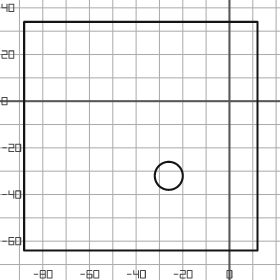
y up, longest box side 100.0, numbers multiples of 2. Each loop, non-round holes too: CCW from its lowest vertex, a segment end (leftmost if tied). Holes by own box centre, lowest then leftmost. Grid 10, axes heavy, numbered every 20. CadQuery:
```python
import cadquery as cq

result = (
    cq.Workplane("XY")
    .moveTo(-88.0, -64.0)
    .lineTo(12.0, -64.0)
    .lineTo(12.0, 34.0)
    .lineTo(-88.0, 34.0)
    .close()
    .moveTo(-26.0, -32.0)
    .circle(6.0)
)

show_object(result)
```